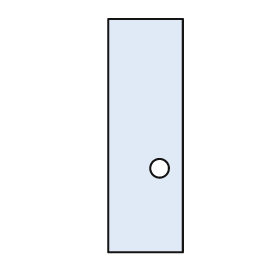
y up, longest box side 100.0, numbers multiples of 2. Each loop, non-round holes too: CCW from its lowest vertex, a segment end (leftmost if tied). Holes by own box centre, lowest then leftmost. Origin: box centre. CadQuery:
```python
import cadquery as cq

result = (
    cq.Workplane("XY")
    .moveTo(-16.0, -50.0)
    .lineTo(16.0, -50.0)
    .lineTo(16.0, 50.0)
    .lineTo(-16.0, 50.0)
    .close()
    .moveTo(6.0, -14.0)
    .circle(4.0)
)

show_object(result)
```